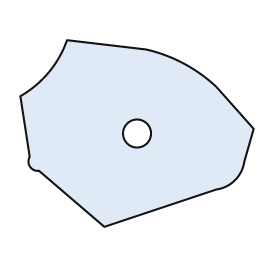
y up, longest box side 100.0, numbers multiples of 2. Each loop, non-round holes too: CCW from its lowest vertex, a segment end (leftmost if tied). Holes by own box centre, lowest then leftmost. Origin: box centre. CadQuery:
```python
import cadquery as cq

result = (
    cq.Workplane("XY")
    .moveTo(-14.0, -40.0)
    .lineTo(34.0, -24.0)
    .threePointArc((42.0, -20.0), (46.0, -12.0))
    .lineTo(50.0, 2.0)
    .lineTo(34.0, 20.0)
    .threePointArc((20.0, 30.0), (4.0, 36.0))
    .lineTo(-30.0, 40.0)
    .threePointArc((-38.0, 26.0), (-50.0, 16.0))
    .lineTo(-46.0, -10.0)
    .threePointArc((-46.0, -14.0), (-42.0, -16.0))
    .close()
    .moveTo(0.0, 0.0)
    .circle(6.0)
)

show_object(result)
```